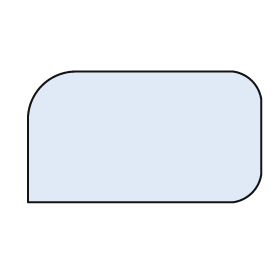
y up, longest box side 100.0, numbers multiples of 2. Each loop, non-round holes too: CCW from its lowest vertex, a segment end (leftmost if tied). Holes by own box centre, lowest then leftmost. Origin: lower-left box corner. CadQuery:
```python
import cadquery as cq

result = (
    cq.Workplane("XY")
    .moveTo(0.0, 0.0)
    .lineTo(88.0, 0.0)
    .threePointArc((96.0, 4.0), (100.0, 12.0))
    .lineTo(100.0, 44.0)
    .threePointArc((96.0, 52.0), (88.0, 56.0))
    .lineTo(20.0, 56.0)
    .threePointArc((6.0, 50.0), (0.0, 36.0))
    .close()
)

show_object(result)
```